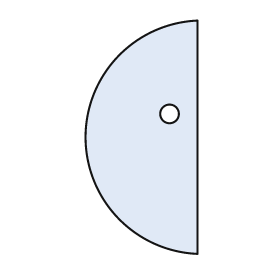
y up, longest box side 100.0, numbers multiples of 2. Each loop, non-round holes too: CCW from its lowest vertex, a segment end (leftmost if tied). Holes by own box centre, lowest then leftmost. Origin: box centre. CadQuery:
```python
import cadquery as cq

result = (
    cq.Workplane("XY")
    .moveTo(24.0, -50.0)
    .lineTo(24.0, 50.0)
    .threePointArc((-24.0, 0.0), (24.0, -50.0))
    .close()
    .moveTo(12.0, 10.0)
    .circle(4.0)
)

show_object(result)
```